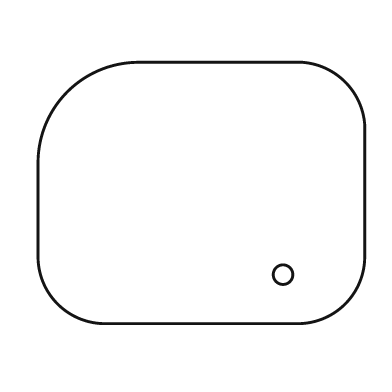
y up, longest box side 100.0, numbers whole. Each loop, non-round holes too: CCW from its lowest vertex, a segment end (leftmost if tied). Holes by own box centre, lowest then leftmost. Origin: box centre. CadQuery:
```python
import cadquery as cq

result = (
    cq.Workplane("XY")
    .moveTo(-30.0, -40.0)
    .lineTo(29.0, -40.0)
    .threePointArc((44.0, -34.0), (50.0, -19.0))
    .lineTo(50.0, 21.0)
    .threePointArc((44.0, 34.0), (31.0, 40.0))
    .lineTo(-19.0, 40.0)
    .threePointArc((-41.0, 31.0), (-50.0, 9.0))
    .lineTo(-50.0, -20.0)
    .threePointArc((-44.0, -34.0), (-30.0, -40.0))
    .close()
    .moveTo(25.0, -25.0)
    .circle(3.0)
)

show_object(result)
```